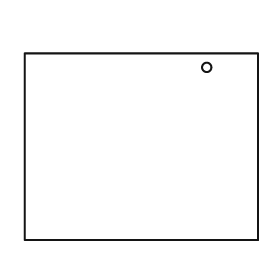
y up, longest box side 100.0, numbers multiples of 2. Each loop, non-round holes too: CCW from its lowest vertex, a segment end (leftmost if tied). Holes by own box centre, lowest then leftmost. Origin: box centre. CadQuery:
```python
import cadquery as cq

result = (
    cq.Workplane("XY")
    .moveTo(-50.0, -40.0)
    .lineTo(50.0, -40.0)
    .lineTo(50.0, 40.0)
    .lineTo(-50.0, 40.0)
    .close()
    .moveTo(28.0, 34.0)
    .circle(2.0)
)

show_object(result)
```